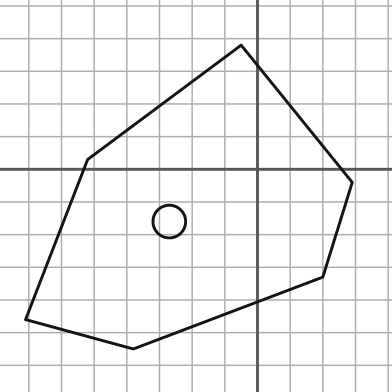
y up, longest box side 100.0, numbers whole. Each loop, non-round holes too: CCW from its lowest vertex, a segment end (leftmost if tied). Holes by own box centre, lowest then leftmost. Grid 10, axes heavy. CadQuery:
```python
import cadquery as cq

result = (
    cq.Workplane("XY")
    .moveTo(-38.0, -55.0)
    .lineTo(20.0, -33.0)
    .lineTo(29.0, -4.0)
    .lineTo(-5.0, 38.0)
    .lineTo(-52.0, 3.0)
    .lineTo(-71.0, -46.0)
    .close()
    .moveTo(-27.0, -16.0)
    .circle(5.0)
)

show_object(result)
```